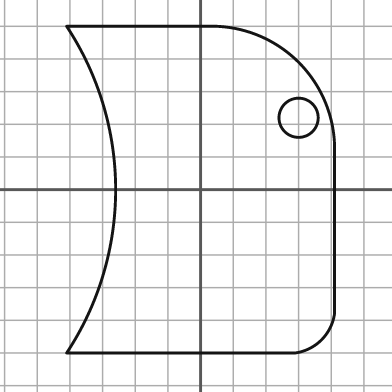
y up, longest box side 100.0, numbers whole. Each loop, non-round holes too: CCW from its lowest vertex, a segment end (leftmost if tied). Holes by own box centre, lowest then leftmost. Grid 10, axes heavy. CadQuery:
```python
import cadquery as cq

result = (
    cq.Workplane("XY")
    .moveTo(-41.0, -50.0)
    .lineTo(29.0, -50.0)
    .threePointArc((37.0, -46.0), (41.0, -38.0))
    .lineTo(41.0, 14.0)
    .threePointArc((30.0, 39.0), (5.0, 50.0))
    .lineTo(-41.0, 50.0)
    .threePointArc((-26.0, 0.0), (-41.0, -50.0))
    .close()
    .moveTo(30.0, 22.0)
    .circle(6.0)
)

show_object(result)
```